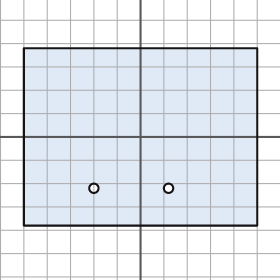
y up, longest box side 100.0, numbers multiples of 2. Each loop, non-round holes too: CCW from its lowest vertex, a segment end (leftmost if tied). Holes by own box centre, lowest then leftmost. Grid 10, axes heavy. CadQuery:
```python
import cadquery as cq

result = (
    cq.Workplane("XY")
    .moveTo(-50.0, -38.0)
    .lineTo(50.0, -38.0)
    .lineTo(50.0, 38.0)
    .lineTo(-50.0, 38.0)
    .close()
    .moveTo(-20.0, -22.0)
    .circle(2.0)
    .moveTo(12.0, -22.0)
    .circle(2.0)
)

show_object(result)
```